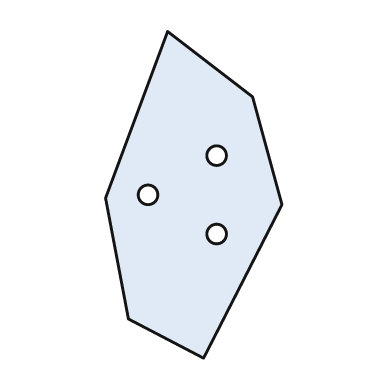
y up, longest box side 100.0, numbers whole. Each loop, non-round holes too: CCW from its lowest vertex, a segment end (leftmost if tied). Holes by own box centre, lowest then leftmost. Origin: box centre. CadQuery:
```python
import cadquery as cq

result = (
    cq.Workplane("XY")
    .moveTo(3.0, -50.0)
    .lineTo(27.0, -3.0)
    .lineTo(18.0, 30.0)
    .lineTo(-8.0, 50.0)
    .lineTo(-27.0, -1.0)
    .lineTo(-20.0, -38.0)
    .close()
    .moveTo(7.0, -12.0)
    .circle(3.0)
    .moveTo(-14.0, 0.0)
    .circle(3.0)
    .moveTo(7.0, 12.0)
    .circle(3.0)
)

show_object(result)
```